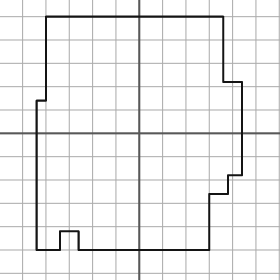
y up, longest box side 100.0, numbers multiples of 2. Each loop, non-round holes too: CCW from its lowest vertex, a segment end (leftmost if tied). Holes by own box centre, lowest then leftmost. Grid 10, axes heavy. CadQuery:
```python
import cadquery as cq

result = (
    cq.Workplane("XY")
    .moveTo(-44.0, -50.0)
    .lineTo(-34.0, -50.0)
    .lineTo(-34.0, -42.0)
    .lineTo(-26.0, -42.0)
    .lineTo(-26.0, -50.0)
    .lineTo(30.0, -50.0)
    .lineTo(30.0, -26.0)
    .lineTo(38.0, -26.0)
    .lineTo(38.0, -18.0)
    .lineTo(44.0, -18.0)
    .lineTo(44.0, 22.0)
    .lineTo(36.0, 22.0)
    .lineTo(36.0, 50.0)
    .lineTo(-40.0, 50.0)
    .lineTo(-40.0, 14.0)
    .lineTo(-44.0, 14.0)
    .close()
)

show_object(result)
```